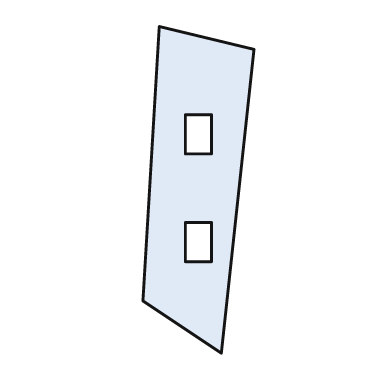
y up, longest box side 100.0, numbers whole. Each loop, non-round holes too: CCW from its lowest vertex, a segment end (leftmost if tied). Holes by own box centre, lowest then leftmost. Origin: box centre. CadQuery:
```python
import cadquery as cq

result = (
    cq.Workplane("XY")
    .moveTo(7.0, -50.0)
    .lineTo(17.0, 43.0)
    .lineTo(-12.0, 50.0)
    .lineTo(-17.0, -34.0)
    .close()
    .moveTo(-4.0, -22.0)
    .lineTo(4.0, -22.0)
    .lineTo(4.0, -10.0)
    .lineTo(-4.0, -10.0)
    .close()
    .moveTo(-4.0, 11.0)
    .lineTo(4.0, 11.0)
    .lineTo(4.0, 23.0)
    .lineTo(-4.0, 23.0)
    .close()
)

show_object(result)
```